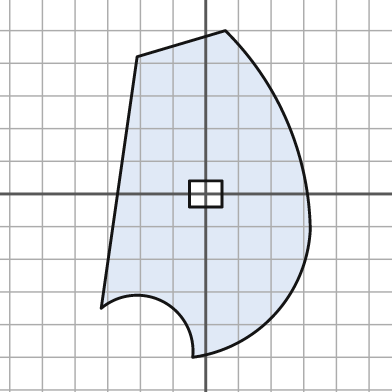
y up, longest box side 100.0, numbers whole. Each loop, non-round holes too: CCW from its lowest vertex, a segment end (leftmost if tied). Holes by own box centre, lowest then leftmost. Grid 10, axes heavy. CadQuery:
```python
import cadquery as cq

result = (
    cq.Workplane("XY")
    .moveTo(-4.0, -50.0)
    .threePointArc((21.0, -37.0), (32.0, -11.0))
    .threePointArc((25.0, 22.0), (6.0, 50.0))
    .lineTo(-21.0, 42.0)
    .lineTo(-32.0, -35.0)
    .threePointArc((-13.0, -33.0), (-4.0, -50.0))
    .close()
    .moveTo(-5.0, -4.0)
    .lineTo(5.0, -4.0)
    .lineTo(5.0, 4.0)
    .lineTo(-5.0, 4.0)
    .close()
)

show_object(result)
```